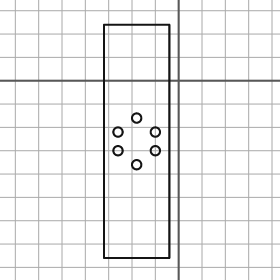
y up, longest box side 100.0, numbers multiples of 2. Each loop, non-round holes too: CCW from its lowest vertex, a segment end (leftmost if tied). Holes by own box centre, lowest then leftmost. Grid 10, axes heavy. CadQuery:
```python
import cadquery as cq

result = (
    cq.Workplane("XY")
    .moveTo(-32.0, -76.0)
    .lineTo(-4.0, -76.0)
    .lineTo(-4.0, 24.0)
    .lineTo(-32.0, 24.0)
    .close()
    .moveTo(-18.0, -36.0)
    .circle(2.0)
    .moveTo(-26.0, -30.0)
    .circle(2.0)
    .moveTo(-10.0, -30.0)
    .circle(2.0)
    .moveTo(-26.0, -22.0)
    .circle(2.0)
    .moveTo(-10.0, -22.0)
    .circle(2.0)
    .moveTo(-18.0, -16.0)
    .circle(2.0)
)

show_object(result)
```